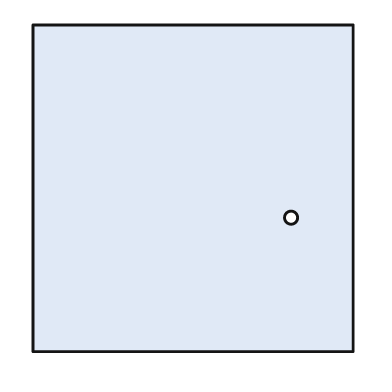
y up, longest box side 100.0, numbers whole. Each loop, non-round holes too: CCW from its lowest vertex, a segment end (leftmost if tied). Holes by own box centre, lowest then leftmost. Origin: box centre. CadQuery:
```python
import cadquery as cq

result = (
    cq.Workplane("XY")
    .moveTo(-49.0, -50.0)
    .lineTo(49.0, -50.0)
    .lineTo(49.0, 50.0)
    .lineTo(-49.0, 50.0)
    .close()
    .moveTo(30.0, -9.0)
    .circle(2.0)
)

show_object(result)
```